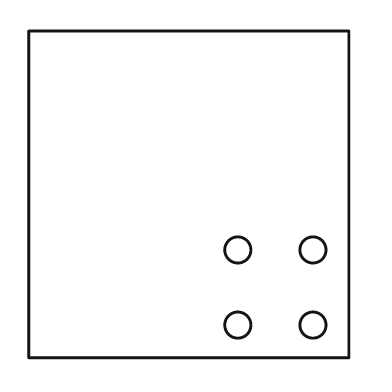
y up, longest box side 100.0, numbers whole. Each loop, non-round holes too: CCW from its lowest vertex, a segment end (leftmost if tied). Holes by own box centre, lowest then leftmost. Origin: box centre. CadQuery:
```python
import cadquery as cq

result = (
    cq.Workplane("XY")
    .moveTo(-49.0, -50.0)
    .lineTo(49.0, -50.0)
    .lineTo(49.0, 50.0)
    .lineTo(-49.0, 50.0)
    .close()
    .moveTo(15.0, -40.0)
    .circle(4.0)
    .moveTo(38.0, -40.0)
    .circle(4.0)
    .moveTo(15.0, -17.0)
    .circle(4.0)
    .moveTo(38.0, -17.0)
    .circle(4.0)
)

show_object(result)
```